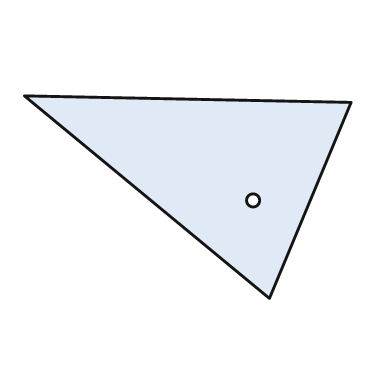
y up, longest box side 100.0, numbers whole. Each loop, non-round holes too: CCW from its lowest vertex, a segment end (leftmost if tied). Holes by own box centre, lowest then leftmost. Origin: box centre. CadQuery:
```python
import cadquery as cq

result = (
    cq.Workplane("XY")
    .moveTo(25.0, -31.0)
    .lineTo(50.0, 29.0)
    .lineTo(-50.0, 31.0)
    .close()
    .moveTo(20.0, -1.0)
    .circle(2.0)
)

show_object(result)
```